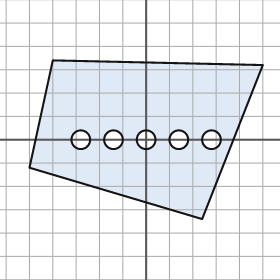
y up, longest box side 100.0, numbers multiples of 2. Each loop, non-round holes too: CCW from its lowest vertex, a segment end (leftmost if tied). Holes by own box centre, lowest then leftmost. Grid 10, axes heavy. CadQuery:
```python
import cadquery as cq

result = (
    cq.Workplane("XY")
    .moveTo(24.0, -34.0)
    .lineTo(50.0, 32.0)
    .lineTo(-40.0, 34.0)
    .lineTo(-50.0, -12.0)
    .close()
    .moveTo(-28.0, 0.0)
    .circle(4.0)
    .moveTo(-14.0, 0.0)
    .circle(4.0)
    .moveTo(0.0, 0.0)
    .circle(4.0)
    .moveTo(14.0, 0.0)
    .circle(4.0)
    .moveTo(28.0, 0.0)
    .circle(4.0)
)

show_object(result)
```